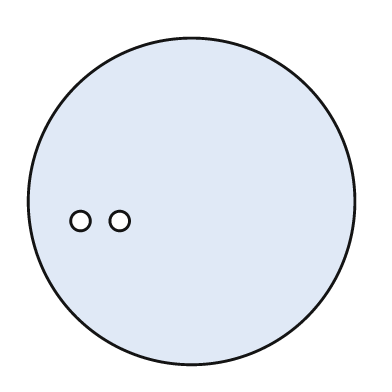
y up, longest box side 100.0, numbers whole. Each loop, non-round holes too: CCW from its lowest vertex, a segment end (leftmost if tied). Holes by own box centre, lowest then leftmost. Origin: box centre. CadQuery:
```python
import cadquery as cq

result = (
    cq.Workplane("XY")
    .moveTo(0.0, 0.0)
    .circle(50.0)
    .moveTo(-34.0, -6.0)
    .circle(3.0)
    .moveTo(-22.0, -6.0)
    .circle(3.0)
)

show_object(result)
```